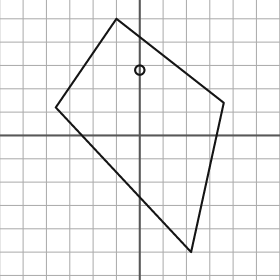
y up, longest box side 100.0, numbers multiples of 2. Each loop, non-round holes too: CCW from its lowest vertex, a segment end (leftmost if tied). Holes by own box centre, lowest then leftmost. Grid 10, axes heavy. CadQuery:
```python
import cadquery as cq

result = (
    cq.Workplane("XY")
    .moveTo(22.0, -50.0)
    .lineTo(36.0, 14.0)
    .lineTo(-10.0, 50.0)
    .lineTo(-36.0, 12.0)
    .close()
    .moveTo(0.0, 28.0)
    .circle(2.0)
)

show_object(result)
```